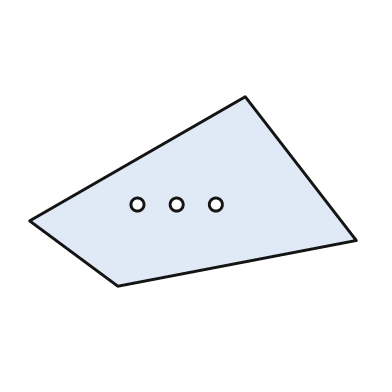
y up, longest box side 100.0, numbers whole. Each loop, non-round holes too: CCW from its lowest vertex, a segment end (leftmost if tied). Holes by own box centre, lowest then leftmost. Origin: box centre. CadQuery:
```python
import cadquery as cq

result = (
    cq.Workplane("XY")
    .moveTo(-23.0, -29.0)
    .lineTo(50.0, -15.0)
    .lineTo(16.0, 29.0)
    .lineTo(-50.0, -9.0)
    .close()
    .moveTo(-17.0, -4.0)
    .circle(2.0)
    .moveTo(-5.0, -4.0)
    .circle(2.0)
    .moveTo(7.0, -4.0)
    .circle(2.0)
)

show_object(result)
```